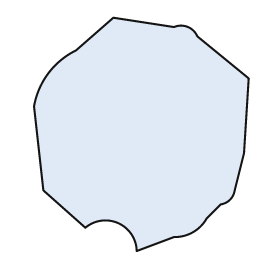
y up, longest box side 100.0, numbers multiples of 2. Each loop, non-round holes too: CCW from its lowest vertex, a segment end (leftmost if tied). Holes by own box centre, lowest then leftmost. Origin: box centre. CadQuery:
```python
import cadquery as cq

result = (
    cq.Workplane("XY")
    .moveTo(-2.0, -50.0)
    .lineTo(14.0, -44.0)
    .threePointArc((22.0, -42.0), (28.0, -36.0))
    .lineTo(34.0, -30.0)
    .threePointArc((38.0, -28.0), (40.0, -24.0))
    .lineTo(44.0, -8.0)
    .lineTo(46.0, 24.0)
    .lineTo(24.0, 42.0)
    .threePointArc((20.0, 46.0), (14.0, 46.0))
    .lineTo(-12.0, 50.0)
    .lineTo(-28.0, 36.0)
    .threePointArc((-40.0, 26.0), (-46.0, 12.0))
    .lineTo(-42.0, -24.0)
    .lineTo(-24.0, -40.0)
    .threePointArc((-10.0, -38.0), (-2.0, -50.0))
    .close()
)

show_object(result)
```